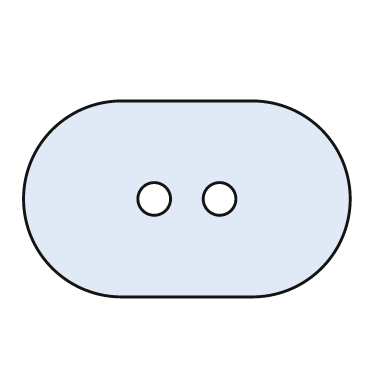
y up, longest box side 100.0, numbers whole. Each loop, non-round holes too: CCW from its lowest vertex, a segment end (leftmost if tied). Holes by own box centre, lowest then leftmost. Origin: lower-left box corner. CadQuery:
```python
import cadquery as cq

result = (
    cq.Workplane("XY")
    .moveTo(30.0, 0.0)
    .lineTo(70.0, 0.0)
    .threePointArc((100.0, 30.0), (70.0, 60.0))
    .lineTo(30.0, 60.0)
    .threePointArc((0.0, 30.0), (30.0, 0.0))
    .close()
    .moveTo(40.0, 30.0)
    .circle(5.0)
    .moveTo(60.0, 30.0)
    .circle(5.0)
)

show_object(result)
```